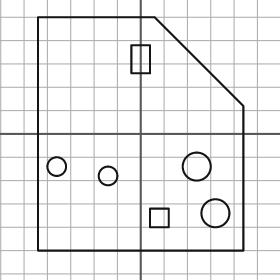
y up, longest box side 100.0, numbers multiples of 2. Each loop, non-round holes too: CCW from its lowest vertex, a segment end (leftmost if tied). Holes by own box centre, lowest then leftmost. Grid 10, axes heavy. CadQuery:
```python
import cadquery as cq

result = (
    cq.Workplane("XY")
    .moveTo(-44.0, -50.0)
    .lineTo(44.0, -50.0)
    .lineTo(44.0, 12.0)
    .lineTo(6.0, 50.0)
    .lineTo(-44.0, 50.0)
    .close()
    .moveTo(4.0, -40.0)
    .lineTo(12.0, -40.0)
    .lineTo(12.0, -32.0)
    .lineTo(4.0, -32.0)
    .close()
    .moveTo(32.0, -34.0)
    .circle(6.0)
    .moveTo(-14.0, -18.0)
    .circle(4.0)
    .moveTo(-36.0, -14.0)
    .circle(4.0)
    .moveTo(24.0, -14.0)
    .circle(6.0)
    .moveTo(-4.0, 26.0)
    .lineTo(4.0, 26.0)
    .lineTo(4.0, 38.0)
    .lineTo(-4.0, 38.0)
    .close()
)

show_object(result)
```